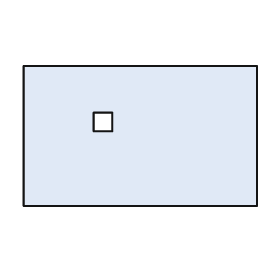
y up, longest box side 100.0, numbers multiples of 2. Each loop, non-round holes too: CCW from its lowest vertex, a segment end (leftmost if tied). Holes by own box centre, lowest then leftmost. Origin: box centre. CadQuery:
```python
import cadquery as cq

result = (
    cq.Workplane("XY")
    .moveTo(-50.0, -30.0)
    .lineTo(50.0, -30.0)
    .lineTo(50.0, 30.0)
    .lineTo(-50.0, 30.0)
    .close()
    .moveTo(-20.0, 2.0)
    .lineTo(-12.0, 2.0)
    .lineTo(-12.0, 10.0)
    .lineTo(-20.0, 10.0)
    .close()
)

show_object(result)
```